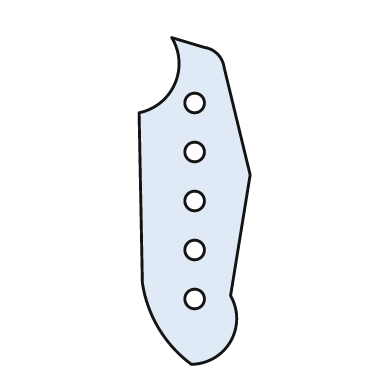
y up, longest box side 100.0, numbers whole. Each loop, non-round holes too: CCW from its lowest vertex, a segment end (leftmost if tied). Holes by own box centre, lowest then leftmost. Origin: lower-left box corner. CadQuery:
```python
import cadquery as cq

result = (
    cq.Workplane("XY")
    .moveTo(16.0, 0.0)
    .threePointArc((28.0, 7.0), (28.0, 21.0))
    .lineTo(34.0, 58.0)
    .lineTo(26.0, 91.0)
    .threePointArc((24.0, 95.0), (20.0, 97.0))
    .lineTo(10.0, 100.0)
    .threePointArc((11.0, 86.0), (0.0, 77.0))
    .lineTo(1.0, 25.0)
    .threePointArc((6.0, 11.0), (16.0, 0.0))
    .close()
    .moveTo(17.0, 20.0)
    .circle(3.0)
    .moveTo(17.0, 35.0)
    .circle(3.0)
    .moveTo(17.0, 50.0)
    .circle(3.0)
    .moveTo(17.0, 65.0)
    .circle(3.0)
    .moveTo(17.0, 80.0)
    .circle(3.0)
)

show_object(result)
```